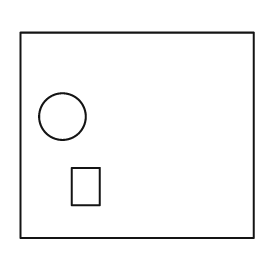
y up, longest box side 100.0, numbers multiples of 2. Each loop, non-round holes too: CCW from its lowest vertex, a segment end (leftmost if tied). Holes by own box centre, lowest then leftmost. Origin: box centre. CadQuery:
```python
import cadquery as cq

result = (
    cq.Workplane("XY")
    .moveTo(-50.0, -44.0)
    .lineTo(50.0, -44.0)
    .lineTo(50.0, 44.0)
    .lineTo(-50.0, 44.0)
    .close()
    .moveTo(-28.0, -30.0)
    .lineTo(-16.0, -30.0)
    .lineTo(-16.0, -14.0)
    .lineTo(-28.0, -14.0)
    .close()
    .moveTo(-32.0, 8.0)
    .circle(10.0)
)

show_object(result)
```